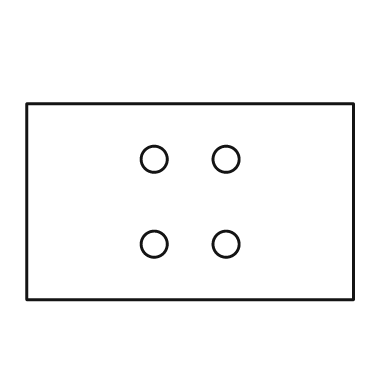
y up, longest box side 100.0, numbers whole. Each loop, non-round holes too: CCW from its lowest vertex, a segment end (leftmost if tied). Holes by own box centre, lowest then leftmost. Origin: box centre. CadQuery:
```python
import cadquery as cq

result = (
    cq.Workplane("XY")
    .moveTo(-50.0, -30.0)
    .lineTo(50.0, -30.0)
    .lineTo(50.0, 30.0)
    .lineTo(-50.0, 30.0)
    .close()
    .moveTo(-11.0, -13.0)
    .circle(4.0)
    .moveTo(11.0, -13.0)
    .circle(4.0)
    .moveTo(-11.0, 13.0)
    .circle(4.0)
    .moveTo(11.0, 13.0)
    .circle(4.0)
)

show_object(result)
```